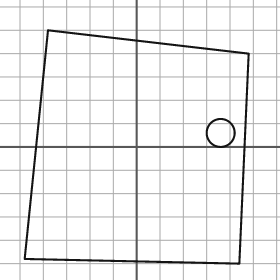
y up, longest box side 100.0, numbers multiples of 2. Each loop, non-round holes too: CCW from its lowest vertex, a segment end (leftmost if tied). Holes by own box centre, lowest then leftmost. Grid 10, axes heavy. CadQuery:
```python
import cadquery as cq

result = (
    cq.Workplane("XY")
    .moveTo(44.0, -50.0)
    .lineTo(48.0, 40.0)
    .lineTo(-38.0, 50.0)
    .lineTo(-48.0, -48.0)
    .close()
    .moveTo(36.0, 6.0)
    .circle(6.0)
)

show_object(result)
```